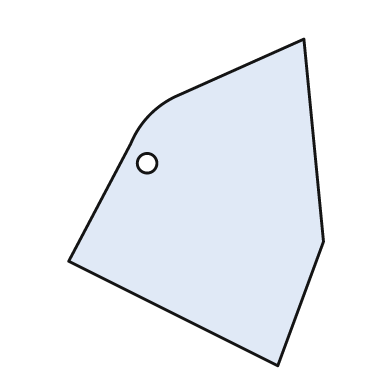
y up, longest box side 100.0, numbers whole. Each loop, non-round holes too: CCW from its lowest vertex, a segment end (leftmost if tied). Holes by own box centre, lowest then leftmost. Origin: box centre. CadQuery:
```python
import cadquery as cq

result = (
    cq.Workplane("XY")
    .moveTo(25.0, -50.0)
    .lineTo(39.0, -12.0)
    .lineTo(33.0, 50.0)
    .lineTo(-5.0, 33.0)
    .threePointArc((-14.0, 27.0), (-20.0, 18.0))
    .lineTo(-39.0, -18.0)
    .close()
    .moveTo(-15.0, 12.0)
    .circle(3.0)
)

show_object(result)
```